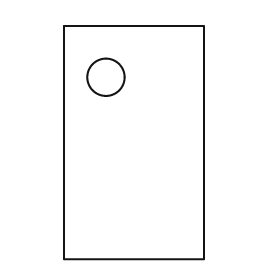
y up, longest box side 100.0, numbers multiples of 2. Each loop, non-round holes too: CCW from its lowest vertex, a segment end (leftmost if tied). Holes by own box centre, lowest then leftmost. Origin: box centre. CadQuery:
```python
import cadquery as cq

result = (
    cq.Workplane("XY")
    .moveTo(-30.0, -50.0)
    .lineTo(30.0, -50.0)
    .lineTo(30.0, 50.0)
    .lineTo(-30.0, 50.0)
    .close()
    .moveTo(-12.0, 28.0)
    .circle(8.0)
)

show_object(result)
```